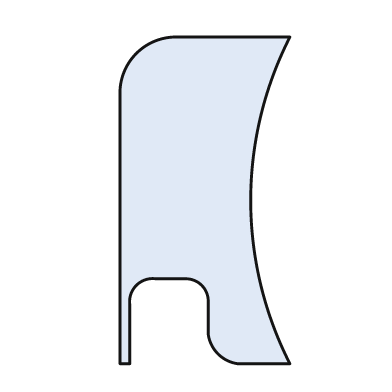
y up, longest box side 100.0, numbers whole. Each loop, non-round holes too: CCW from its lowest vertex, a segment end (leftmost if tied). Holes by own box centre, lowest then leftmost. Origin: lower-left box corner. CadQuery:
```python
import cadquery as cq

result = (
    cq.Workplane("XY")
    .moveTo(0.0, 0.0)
    .lineTo(3.0, 0.0)
    .lineTo(3.0, 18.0)
    .threePointArc((5.0, 24.0), (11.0, 26.0))
    .lineTo(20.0, 26.0)
    .threePointArc((25.0, 24.0), (27.0, 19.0))
    .lineTo(27.0, 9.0)
    .threePointArc((30.0, 3.0), (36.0, 0.0))
    .lineTo(52.0, 0.0)
    .threePointArc((40.0, 50.0), (52.0, 100.0))
    .lineTo(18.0, 100.0)
    .threePointArc((5.0, 95.0), (0.0, 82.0))
    .close()
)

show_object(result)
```